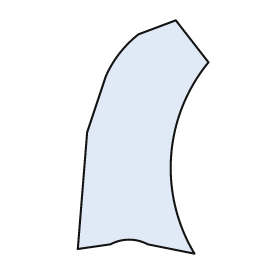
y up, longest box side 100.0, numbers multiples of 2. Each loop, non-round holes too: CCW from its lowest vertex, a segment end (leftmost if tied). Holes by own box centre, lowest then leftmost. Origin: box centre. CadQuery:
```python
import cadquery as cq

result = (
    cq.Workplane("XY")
    .moveTo(22.0, -50.0)
    .threePointArc((12.0, -8.0), (28.0, 32.0))
    .lineTo(14.0, 50.0)
    .lineTo(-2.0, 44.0)
    .threePointArc((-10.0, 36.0), (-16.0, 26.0))
    .lineTo(-24.0, 2.0)
    .lineTo(-28.0, -48.0)
    .lineTo(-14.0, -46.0)
    .threePointArc((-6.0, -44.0), (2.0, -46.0))
    .close()
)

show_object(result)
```